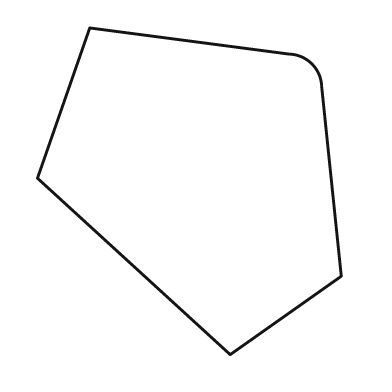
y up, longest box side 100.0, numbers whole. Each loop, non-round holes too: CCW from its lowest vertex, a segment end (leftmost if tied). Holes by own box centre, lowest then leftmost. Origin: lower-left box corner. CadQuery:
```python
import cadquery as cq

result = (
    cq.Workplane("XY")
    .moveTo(59.0, 0.0)
    .lineTo(93.0, 24.0)
    .lineTo(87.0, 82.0)
    .threePointArc((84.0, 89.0), (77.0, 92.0))
    .lineTo(16.0, 100.0)
    .lineTo(0.0, 54.0)
    .close()
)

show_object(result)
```